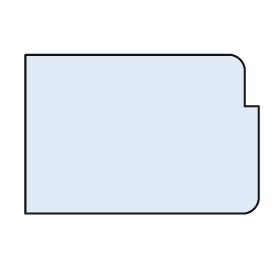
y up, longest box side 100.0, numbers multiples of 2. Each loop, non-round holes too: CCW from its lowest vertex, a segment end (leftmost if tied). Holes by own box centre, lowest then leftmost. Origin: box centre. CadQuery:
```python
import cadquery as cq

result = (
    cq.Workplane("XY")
    .moveTo(-50.0, -34.0)
    .lineTo(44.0, -34.0)
    .threePointArc((48.0, -32.0), (50.0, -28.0))
    .lineTo(50.0, 12.0)
    .lineTo(44.0, 12.0)
    .lineTo(44.0, 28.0)
    .threePointArc((42.0, 32.0), (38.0, 34.0))
    .lineTo(-50.0, 34.0)
    .close()
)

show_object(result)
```